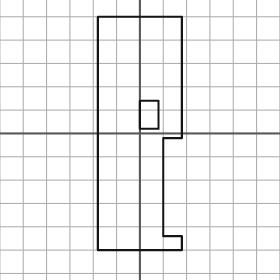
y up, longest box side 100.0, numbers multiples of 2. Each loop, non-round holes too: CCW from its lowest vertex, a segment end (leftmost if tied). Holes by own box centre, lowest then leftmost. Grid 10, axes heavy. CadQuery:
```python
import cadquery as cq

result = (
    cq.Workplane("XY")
    .moveTo(-18.0, -50.0)
    .lineTo(18.0, -50.0)
    .lineTo(18.0, -44.0)
    .lineTo(10.0, -44.0)
    .lineTo(10.0, -2.0)
    .lineTo(18.0, -2.0)
    .lineTo(18.0, 50.0)
    .lineTo(-18.0, 50.0)
    .close()
    .moveTo(0.0, 2.0)
    .lineTo(8.0, 2.0)
    .lineTo(8.0, 14.0)
    .lineTo(0.0, 14.0)
    .close()
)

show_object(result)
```